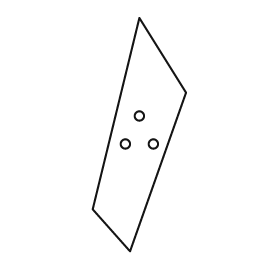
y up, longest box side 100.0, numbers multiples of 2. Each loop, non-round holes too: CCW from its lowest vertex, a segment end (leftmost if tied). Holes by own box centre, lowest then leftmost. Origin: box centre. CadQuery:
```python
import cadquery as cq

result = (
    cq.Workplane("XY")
    .moveTo(-4.0, -50.0)
    .lineTo(20.0, 18.0)
    .lineTo(0.0, 50.0)
    .lineTo(-20.0, -32.0)
    .close()
    .moveTo(-6.0, -4.0)
    .circle(2.0)
    .moveTo(6.0, -4.0)
    .circle(2.0)
    .moveTo(0.0, 8.0)
    .circle(2.0)
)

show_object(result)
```